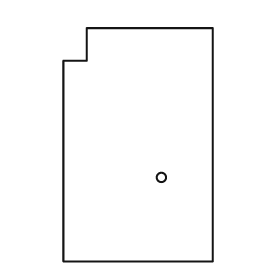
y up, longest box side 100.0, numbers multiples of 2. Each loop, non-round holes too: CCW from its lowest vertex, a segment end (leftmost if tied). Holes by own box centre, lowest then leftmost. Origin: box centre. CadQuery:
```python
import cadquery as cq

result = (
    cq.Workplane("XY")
    .moveTo(-32.0, -50.0)
    .lineTo(32.0, -50.0)
    .lineTo(32.0, 50.0)
    .lineTo(-22.0, 50.0)
    .lineTo(-22.0, 36.0)
    .lineTo(-32.0, 36.0)
    .close()
    .moveTo(10.0, -14.0)
    .circle(2.0)
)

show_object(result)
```